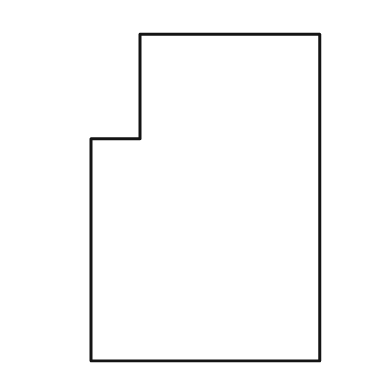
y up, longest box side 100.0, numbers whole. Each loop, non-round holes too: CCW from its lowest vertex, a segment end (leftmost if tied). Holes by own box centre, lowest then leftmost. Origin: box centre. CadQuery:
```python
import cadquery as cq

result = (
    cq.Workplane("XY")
    .moveTo(-35.0, -50.0)
    .lineTo(35.0, -50.0)
    .lineTo(35.0, 50.0)
    .lineTo(-20.0, 50.0)
    .lineTo(-20.0, 18.0)
    .lineTo(-35.0, 18.0)
    .close()
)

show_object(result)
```